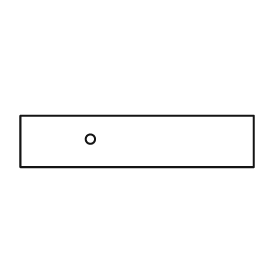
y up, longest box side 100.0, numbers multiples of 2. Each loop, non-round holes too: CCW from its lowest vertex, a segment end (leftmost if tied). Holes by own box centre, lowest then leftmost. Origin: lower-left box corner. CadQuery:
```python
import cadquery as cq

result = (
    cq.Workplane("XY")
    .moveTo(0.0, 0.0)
    .lineTo(100.0, 0.0)
    .lineTo(100.0, 22.0)
    .lineTo(0.0, 22.0)
    .close()
    .moveTo(30.0, 12.0)
    .circle(2.0)
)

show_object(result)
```